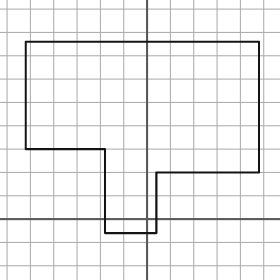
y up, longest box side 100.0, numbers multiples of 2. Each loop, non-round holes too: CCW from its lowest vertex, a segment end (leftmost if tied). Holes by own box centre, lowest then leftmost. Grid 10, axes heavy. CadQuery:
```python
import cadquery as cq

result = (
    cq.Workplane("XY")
    .moveTo(-18.0, -6.0)
    .lineTo(4.0, -6.0)
    .lineTo(4.0, 20.0)
    .lineTo(48.0, 20.0)
    .lineTo(48.0, 76.0)
    .lineTo(-52.0, 76.0)
    .lineTo(-52.0, 30.0)
    .lineTo(-18.0, 30.0)
    .close()
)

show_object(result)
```